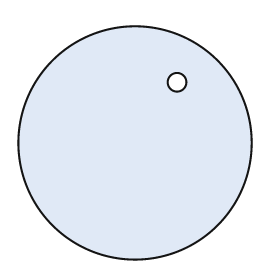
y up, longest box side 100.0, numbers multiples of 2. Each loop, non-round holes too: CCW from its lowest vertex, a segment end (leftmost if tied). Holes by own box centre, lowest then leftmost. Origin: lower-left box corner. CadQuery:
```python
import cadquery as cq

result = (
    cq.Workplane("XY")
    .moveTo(50.0, 50.0)
    .circle(50.0)
    .moveTo(68.0, 76.0)
    .circle(4.0)
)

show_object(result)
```